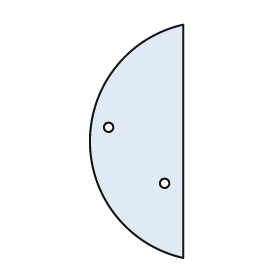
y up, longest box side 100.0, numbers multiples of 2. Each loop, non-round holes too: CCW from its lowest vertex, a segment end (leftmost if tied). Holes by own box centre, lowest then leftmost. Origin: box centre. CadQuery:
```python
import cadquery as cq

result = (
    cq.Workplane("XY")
    .moveTo(20.0, -50.0)
    .lineTo(20.0, 50.0)
    .threePointArc((-20.0, 0.0), (20.0, -50.0))
    .close()
    .moveTo(12.0, -18.0)
    .circle(2.0)
    .moveTo(-12.0, 6.0)
    .circle(2.0)
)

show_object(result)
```